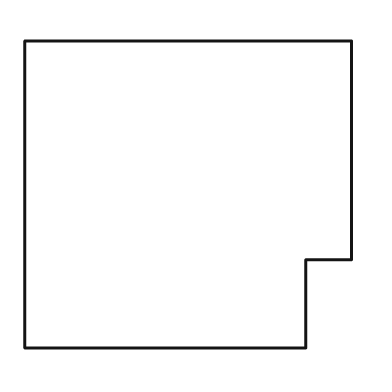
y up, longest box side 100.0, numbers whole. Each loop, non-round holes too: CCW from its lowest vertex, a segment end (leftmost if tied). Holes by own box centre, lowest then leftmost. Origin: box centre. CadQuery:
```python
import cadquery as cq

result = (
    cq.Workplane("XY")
    .moveTo(-50.0, -47.0)
    .lineTo(36.0, -47.0)
    .lineTo(36.0, -20.0)
    .lineTo(50.0, -20.0)
    .lineTo(50.0, 47.0)
    .lineTo(-50.0, 47.0)
    .close()
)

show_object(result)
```